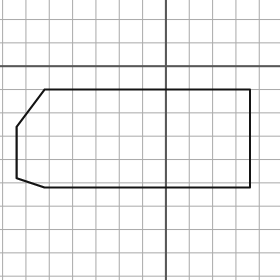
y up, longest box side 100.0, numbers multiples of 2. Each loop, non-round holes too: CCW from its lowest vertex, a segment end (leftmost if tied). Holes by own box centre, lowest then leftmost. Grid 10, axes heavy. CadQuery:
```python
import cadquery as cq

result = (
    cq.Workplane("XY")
    .moveTo(-52.0, -52.0)
    .lineTo(36.0, -52.0)
    .lineTo(36.0, -10.0)
    .lineTo(-52.0, -10.0)
    .lineTo(-64.0, -26.0)
    .lineTo(-64.0, -48.0)
    .close()
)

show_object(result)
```